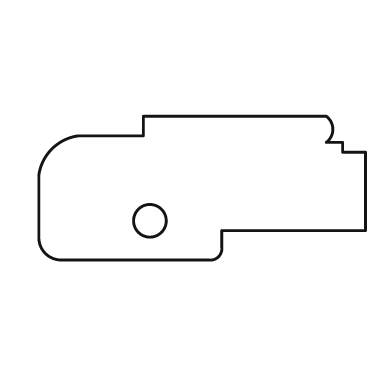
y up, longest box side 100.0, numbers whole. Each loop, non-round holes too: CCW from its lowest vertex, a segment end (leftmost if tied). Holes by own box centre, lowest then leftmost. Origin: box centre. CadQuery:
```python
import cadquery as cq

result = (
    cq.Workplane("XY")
    .moveTo(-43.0, -22.0)
    .lineTo(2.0, -22.0)
    .threePointArc((5.0, -21.0), (6.0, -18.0))
    .lineTo(6.0, -13.0)
    .lineTo(50.0, -13.0)
    .lineTo(50.0, 11.0)
    .lineTo(43.0, 11.0)
    .lineTo(43.0, 14.0)
    .lineTo(38.0, 14.0)
    .threePointArc((40.0, 18.0), (38.0, 22.0))
    .lineTo(-18.0, 22.0)
    .lineTo(-18.0, 16.0)
    .lineTo(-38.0, 16.0)
    .threePointArc((-46.0, 12.0), (-50.0, 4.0))
    .lineTo(-50.0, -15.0)
    .threePointArc((-48.0, -20.0), (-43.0, -22.0))
    .close()
    .moveTo(-16.0, -10.0)
    .circle(5.0)
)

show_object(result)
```